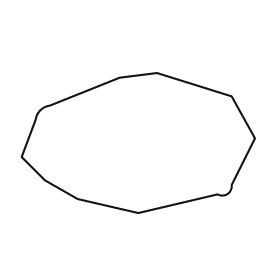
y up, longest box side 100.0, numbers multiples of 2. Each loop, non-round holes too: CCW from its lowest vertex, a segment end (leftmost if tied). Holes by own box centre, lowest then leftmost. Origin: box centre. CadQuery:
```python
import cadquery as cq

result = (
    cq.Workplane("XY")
    .moveTo(0.0, -30.0)
    .lineTo(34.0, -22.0)
    .threePointArc((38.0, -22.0), (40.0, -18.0))
    .lineTo(50.0, 2.0)
    .lineTo(40.0, 20.0)
    .lineTo(8.0, 30.0)
    .lineTo(-8.0, 28.0)
    .lineTo(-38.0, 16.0)
    .threePointArc((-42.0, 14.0), (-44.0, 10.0))
    .lineTo(-50.0, -6.0)
    .lineTo(-40.0, -16.0)
    .lineTo(-26.0, -24.0)
    .close()
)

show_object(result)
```